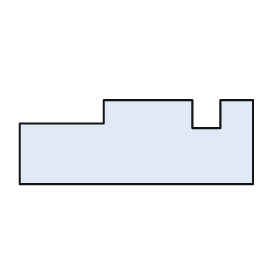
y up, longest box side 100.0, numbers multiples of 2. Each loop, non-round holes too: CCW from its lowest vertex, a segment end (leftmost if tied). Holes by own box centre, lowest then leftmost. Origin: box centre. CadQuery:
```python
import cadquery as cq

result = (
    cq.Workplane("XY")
    .moveTo(-50.0, -18.0)
    .lineTo(50.0, -18.0)
    .lineTo(50.0, 18.0)
    .lineTo(36.0, 18.0)
    .lineTo(36.0, 6.0)
    .lineTo(24.0, 6.0)
    .lineTo(24.0, 18.0)
    .lineTo(-14.0, 18.0)
    .lineTo(-14.0, 8.0)
    .lineTo(-50.0, 8.0)
    .close()
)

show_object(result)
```